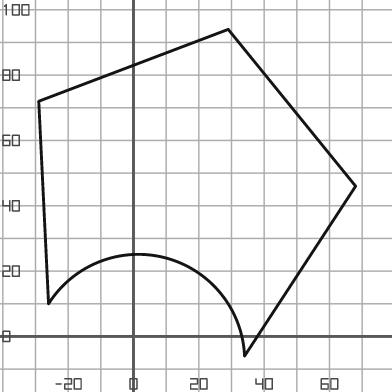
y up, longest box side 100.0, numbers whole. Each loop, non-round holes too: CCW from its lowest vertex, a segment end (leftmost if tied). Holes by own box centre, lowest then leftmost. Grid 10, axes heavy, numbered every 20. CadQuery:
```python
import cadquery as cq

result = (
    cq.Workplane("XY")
    .moveTo(34.0, -6.0)
    .lineTo(68.0, 46.0)
    .lineTo(29.0, 94.0)
    .lineTo(-29.0, 72.0)
    .lineTo(-26.0, 10.0)
    .threePointArc((10.0, 24.0), (34.0, -6.0))
    .close()
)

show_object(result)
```